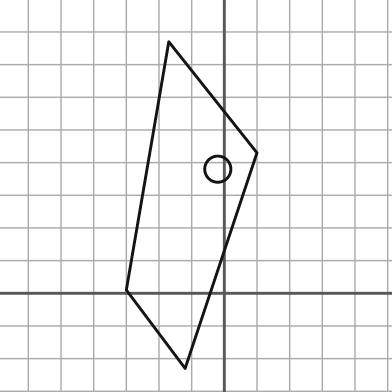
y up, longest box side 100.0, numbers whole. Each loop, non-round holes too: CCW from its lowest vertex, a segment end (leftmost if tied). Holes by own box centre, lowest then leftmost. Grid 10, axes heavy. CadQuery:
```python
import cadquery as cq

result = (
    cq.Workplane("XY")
    .moveTo(-12.0, -23.0)
    .lineTo(10.0, 43.0)
    .lineTo(-17.0, 77.0)
    .lineTo(-30.0, 1.0)
    .close()
    .moveTo(-2.0, 38.0)
    .circle(4.0)
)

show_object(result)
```